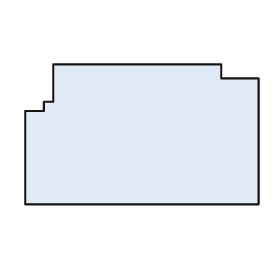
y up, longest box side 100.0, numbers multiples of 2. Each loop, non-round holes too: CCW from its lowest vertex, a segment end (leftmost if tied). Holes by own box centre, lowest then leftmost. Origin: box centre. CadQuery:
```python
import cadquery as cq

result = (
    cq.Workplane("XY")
    .moveTo(-50.0, -30.0)
    .lineTo(50.0, -30.0)
    .lineTo(50.0, 24.0)
    .lineTo(34.0, 24.0)
    .lineTo(34.0, 30.0)
    .lineTo(-38.0, 30.0)
    .lineTo(-38.0, 14.0)
    .lineTo(-42.0, 14.0)
    .lineTo(-42.0, 10.0)
    .lineTo(-50.0, 10.0)
    .close()
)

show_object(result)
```